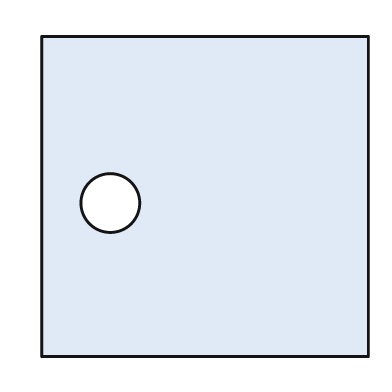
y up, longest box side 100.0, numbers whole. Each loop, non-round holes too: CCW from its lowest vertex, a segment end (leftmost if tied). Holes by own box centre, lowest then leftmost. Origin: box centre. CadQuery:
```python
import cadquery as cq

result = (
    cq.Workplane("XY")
    .moveTo(-50.0, -49.0)
    .lineTo(50.0, -49.0)
    .lineTo(50.0, 49.0)
    .lineTo(-50.0, 49.0)
    .close()
    .moveTo(-29.0, -2.0)
    .circle(9.0)
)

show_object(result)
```